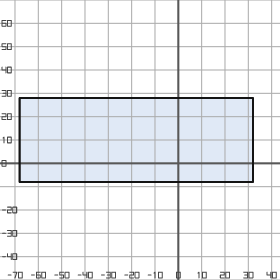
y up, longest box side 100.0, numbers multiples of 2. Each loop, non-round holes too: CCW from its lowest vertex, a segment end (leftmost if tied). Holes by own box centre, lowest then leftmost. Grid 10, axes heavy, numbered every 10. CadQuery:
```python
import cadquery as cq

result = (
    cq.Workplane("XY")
    .moveTo(-68.0, -8.0)
    .lineTo(32.0, -8.0)
    .lineTo(32.0, 28.0)
    .lineTo(-68.0, 28.0)
    .close()
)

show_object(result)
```